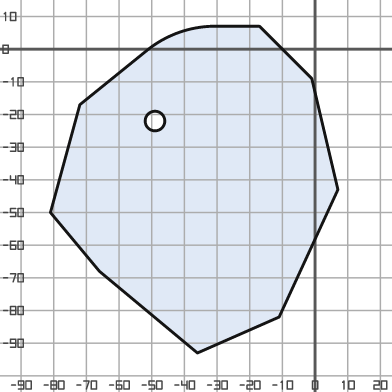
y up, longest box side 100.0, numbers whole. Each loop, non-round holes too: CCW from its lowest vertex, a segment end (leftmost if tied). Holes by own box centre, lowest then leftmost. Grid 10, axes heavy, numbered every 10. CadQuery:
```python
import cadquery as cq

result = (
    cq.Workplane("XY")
    .moveTo(-36.0, -93.0)
    .lineTo(-11.0, -82.0)
    .lineTo(7.0, -43.0)
    .lineTo(-1.0, -9.0)
    .lineTo(-17.0, 7.0)
    .lineTo(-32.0, 7.0)
    .threePointArc((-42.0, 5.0), (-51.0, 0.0))
    .lineTo(-72.0, -17.0)
    .lineTo(-81.0, -50.0)
    .lineTo(-66.0, -68.0)
    .close()
    .moveTo(-49.0, -22.0)
    .circle(3.0)
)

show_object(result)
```